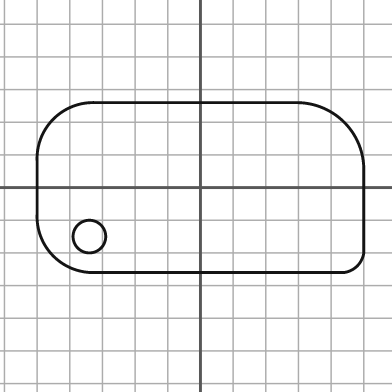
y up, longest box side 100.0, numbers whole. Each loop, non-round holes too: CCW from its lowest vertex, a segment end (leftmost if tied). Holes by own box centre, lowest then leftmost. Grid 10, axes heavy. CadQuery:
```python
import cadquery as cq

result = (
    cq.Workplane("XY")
    .moveTo(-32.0, -26.0)
    .lineTo(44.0, -26.0)
    .threePointArc((48.0, -24.0), (50.0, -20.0))
    .lineTo(50.0, 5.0)
    .threePointArc((44.0, 20.0), (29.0, 26.0))
    .lineTo(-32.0, 26.0)
    .threePointArc((-45.0, 21.0), (-50.0, 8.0))
    .lineTo(-50.0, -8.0)
    .threePointArc((-45.0, -21.0), (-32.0, -26.0))
    .close()
    .moveTo(-34.0, -15.0)
    .circle(5.0)
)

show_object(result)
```